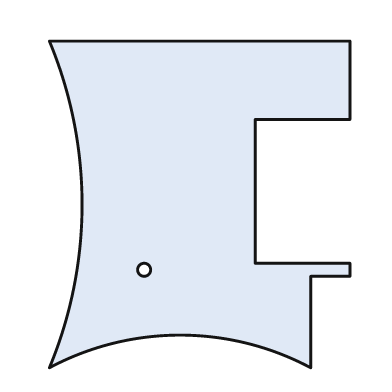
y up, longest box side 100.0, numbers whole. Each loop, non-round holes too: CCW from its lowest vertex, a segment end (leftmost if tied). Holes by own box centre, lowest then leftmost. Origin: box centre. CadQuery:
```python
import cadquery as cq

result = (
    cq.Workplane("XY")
    .moveTo(-46.0, -50.0)
    .threePointArc((-6.0, -40.0), (34.0, -50.0))
    .lineTo(34.0, -22.0)
    .lineTo(46.0, -22.0)
    .lineTo(46.0, -18.0)
    .lineTo(17.0, -18.0)
    .lineTo(17.0, 26.0)
    .lineTo(46.0, 26.0)
    .lineTo(46.0, 50.0)
    .lineTo(-46.0, 50.0)
    .threePointArc((-36.0, 0.0), (-46.0, -50.0))
    .close()
    .moveTo(-17.0, -20.0)
    .circle(2.0)
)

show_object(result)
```